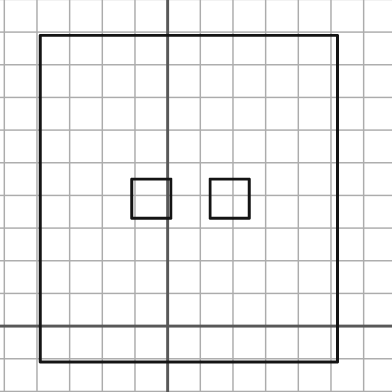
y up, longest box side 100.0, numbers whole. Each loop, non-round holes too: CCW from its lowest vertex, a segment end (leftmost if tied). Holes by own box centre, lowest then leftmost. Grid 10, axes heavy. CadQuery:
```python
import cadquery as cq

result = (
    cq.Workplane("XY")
    .moveTo(-39.0, -11.0)
    .lineTo(52.0, -11.0)
    .lineTo(52.0, 89.0)
    .lineTo(-39.0, 89.0)
    .close()
    .moveTo(-11.0, 33.0)
    .lineTo(1.0, 33.0)
    .lineTo(1.0, 45.0)
    .lineTo(-11.0, 45.0)
    .close()
    .moveTo(13.0, 33.0)
    .lineTo(25.0, 33.0)
    .lineTo(25.0, 45.0)
    .lineTo(13.0, 45.0)
    .close()
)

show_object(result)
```